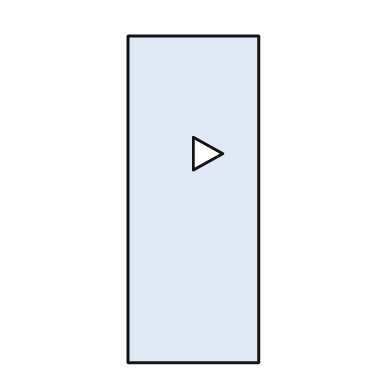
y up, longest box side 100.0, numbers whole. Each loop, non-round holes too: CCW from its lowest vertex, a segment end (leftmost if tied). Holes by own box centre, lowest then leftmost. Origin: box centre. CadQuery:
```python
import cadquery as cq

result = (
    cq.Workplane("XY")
    .moveTo(-20.0, -50.0)
    .lineTo(20.0, -50.0)
    .lineTo(20.0, 50.0)
    .lineTo(-20.0, 50.0)
    .close()
    .moveTo(0.0, 9.0)
    .lineTo(9.0, 14.0)
    .lineTo(0.0, 19.0)
    .close()
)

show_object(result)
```